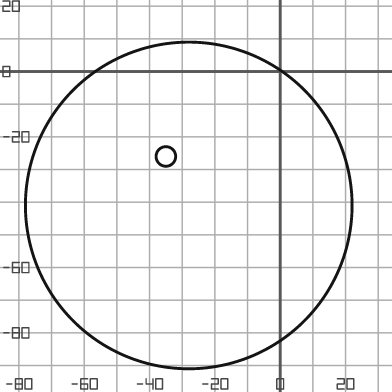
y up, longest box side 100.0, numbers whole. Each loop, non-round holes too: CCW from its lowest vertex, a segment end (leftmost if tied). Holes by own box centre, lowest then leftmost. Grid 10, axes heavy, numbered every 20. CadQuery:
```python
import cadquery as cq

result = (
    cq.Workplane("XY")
    .moveTo(-28.0, -41.0)
    .circle(50.0)
    .moveTo(-35.0, -26.0)
    .circle(3.0)
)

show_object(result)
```